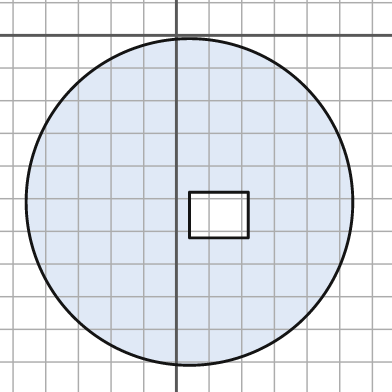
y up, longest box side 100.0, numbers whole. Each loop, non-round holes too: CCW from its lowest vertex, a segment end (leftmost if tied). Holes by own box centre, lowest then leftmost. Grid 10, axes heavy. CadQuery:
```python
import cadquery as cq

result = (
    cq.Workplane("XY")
    .moveTo(4.0, -51.0)
    .circle(50.0)
    .moveTo(4.0, -62.0)
    .lineTo(22.0, -62.0)
    .lineTo(22.0, -48.0)
    .lineTo(4.0, -48.0)
    .close()
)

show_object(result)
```